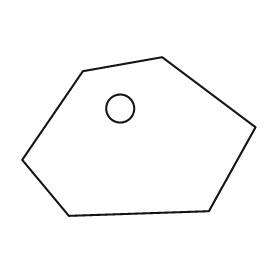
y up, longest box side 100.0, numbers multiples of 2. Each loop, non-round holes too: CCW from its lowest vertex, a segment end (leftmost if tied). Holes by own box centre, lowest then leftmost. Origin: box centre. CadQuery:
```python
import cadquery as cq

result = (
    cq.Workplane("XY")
    .moveTo(-30.0, -34.0)
    .lineTo(30.0, -32.0)
    .lineTo(50.0, 4.0)
    .lineTo(10.0, 34.0)
    .lineTo(-24.0, 28.0)
    .lineTo(-50.0, -10.0)
    .close()
    .moveTo(-8.0, 12.0)
    .circle(6.0)
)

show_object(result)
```